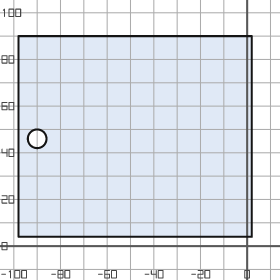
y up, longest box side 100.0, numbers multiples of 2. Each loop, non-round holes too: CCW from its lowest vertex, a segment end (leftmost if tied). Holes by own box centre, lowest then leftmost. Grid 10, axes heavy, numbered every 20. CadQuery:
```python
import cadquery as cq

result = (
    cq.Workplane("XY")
    .moveTo(-98.0, 4.0)
    .lineTo(2.0, 4.0)
    .lineTo(2.0, 90.0)
    .lineTo(-98.0, 90.0)
    .close()
    .moveTo(-90.0, 46.0)
    .circle(4.0)
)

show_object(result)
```